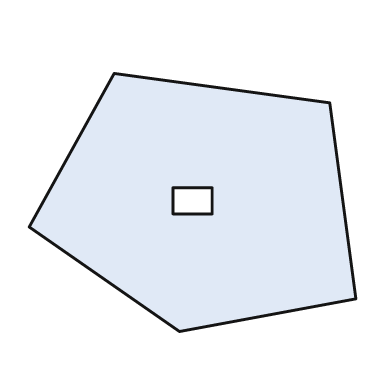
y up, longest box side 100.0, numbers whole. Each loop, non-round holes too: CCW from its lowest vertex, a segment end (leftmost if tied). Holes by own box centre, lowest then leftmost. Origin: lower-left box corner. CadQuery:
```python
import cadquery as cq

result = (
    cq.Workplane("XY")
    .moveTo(46.0, 0.0)
    .lineTo(100.0, 10.0)
    .lineTo(92.0, 70.0)
    .lineTo(26.0, 79.0)
    .lineTo(0.0, 32.0)
    .close()
    .moveTo(44.0, 36.0)
    .lineTo(56.0, 36.0)
    .lineTo(56.0, 44.0)
    .lineTo(44.0, 44.0)
    .close()
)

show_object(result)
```